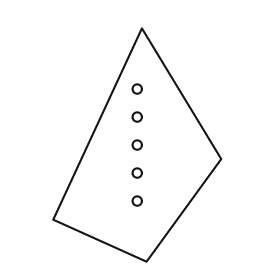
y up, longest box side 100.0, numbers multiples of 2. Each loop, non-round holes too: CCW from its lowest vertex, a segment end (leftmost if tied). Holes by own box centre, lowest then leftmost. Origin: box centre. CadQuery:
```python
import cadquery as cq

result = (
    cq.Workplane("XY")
    .moveTo(4.0, -50.0)
    .lineTo(36.0, -6.0)
    .lineTo(2.0, 50.0)
    .lineTo(-36.0, -32.0)
    .close()
    .moveTo(0.0, -24.0)
    .circle(2.0)
    .moveTo(0.0, -12.0)
    .circle(2.0)
    .moveTo(0.0, 0.0)
    .circle(2.0)
    .moveTo(0.0, 12.0)
    .circle(2.0)
    .moveTo(0.0, 24.0)
    .circle(2.0)
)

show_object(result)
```